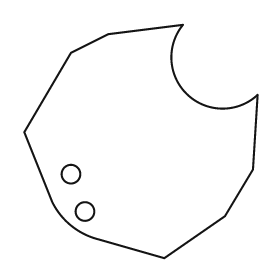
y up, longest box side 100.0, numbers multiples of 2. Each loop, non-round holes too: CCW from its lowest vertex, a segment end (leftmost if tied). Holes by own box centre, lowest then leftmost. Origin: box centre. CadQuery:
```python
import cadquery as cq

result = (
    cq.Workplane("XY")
    .moveTo(10.0, -50.0)
    .lineTo(36.0, -32.0)
    .lineTo(48.0, -12.0)
    .lineTo(50.0, 20.0)
    .threePointArc((20.0, 20.0), (18.0, 50.0))
    .lineTo(-14.0, 46.0)
    .lineTo(-30.0, 38.0)
    .lineTo(-50.0, 4.0)
    .lineTo(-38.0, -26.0)
    .threePointArc((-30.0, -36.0), (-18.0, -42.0))
    .close()
    .moveTo(-24.0, -30.0)
    .circle(4.0)
    .moveTo(-30.0, -14.0)
    .circle(4.0)
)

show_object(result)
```